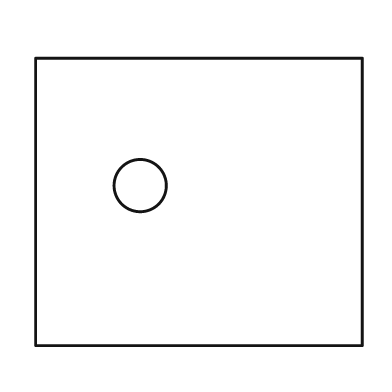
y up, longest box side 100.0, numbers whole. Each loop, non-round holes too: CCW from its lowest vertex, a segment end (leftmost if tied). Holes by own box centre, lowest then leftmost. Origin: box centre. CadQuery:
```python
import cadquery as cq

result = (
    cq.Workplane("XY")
    .moveTo(-50.0, -44.0)
    .lineTo(50.0, -44.0)
    .lineTo(50.0, 44.0)
    .lineTo(-50.0, 44.0)
    .close()
    .moveTo(-18.0, 5.0)
    .circle(8.0)
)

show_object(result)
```